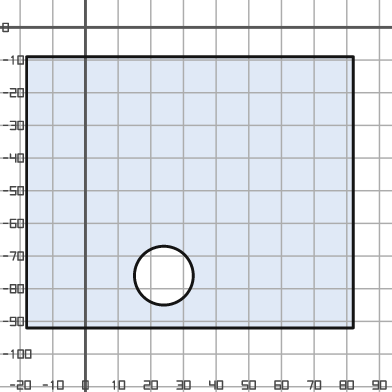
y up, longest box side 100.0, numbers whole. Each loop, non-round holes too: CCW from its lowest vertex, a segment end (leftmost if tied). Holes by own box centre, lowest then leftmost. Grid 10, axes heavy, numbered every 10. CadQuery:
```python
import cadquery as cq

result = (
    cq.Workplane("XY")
    .moveTo(-18.0, -92.0)
    .lineTo(82.0, -92.0)
    .lineTo(82.0, -9.0)
    .lineTo(-18.0, -9.0)
    .close()
    .moveTo(24.0, -76.0)
    .circle(9.0)
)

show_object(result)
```